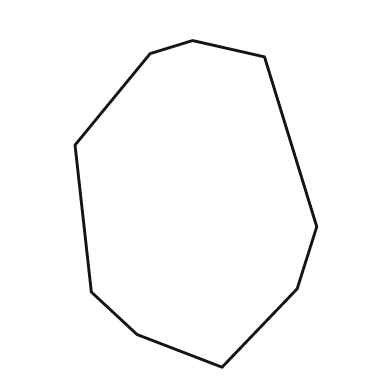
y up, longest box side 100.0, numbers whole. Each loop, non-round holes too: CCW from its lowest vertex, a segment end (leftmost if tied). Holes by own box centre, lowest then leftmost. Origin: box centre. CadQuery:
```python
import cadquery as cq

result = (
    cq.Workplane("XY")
    .moveTo(8.0, -50.0)
    .lineTo(31.0, -26.0)
    .lineTo(37.0, -7.0)
    .lineTo(21.0, 45.0)
    .lineTo(-1.0, 50.0)
    .lineTo(-14.0, 46.0)
    .lineTo(-37.0, 18.0)
    .lineTo(-32.0, -27.0)
    .lineTo(-18.0, -40.0)
    .close()
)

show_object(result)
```